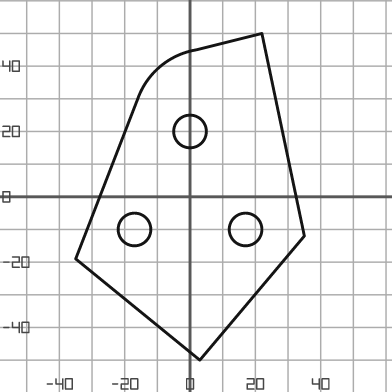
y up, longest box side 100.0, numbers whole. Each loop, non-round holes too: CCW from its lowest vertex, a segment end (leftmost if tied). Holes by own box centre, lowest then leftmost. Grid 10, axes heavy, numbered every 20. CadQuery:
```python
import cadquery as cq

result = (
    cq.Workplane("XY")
    .moveTo(3.0, -50.0)
    .lineTo(35.0, -12.0)
    .lineTo(22.0, 50.0)
    .lineTo(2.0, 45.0)
    .threePointArc((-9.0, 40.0), (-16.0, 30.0))
    .lineTo(-35.0, -19.0)
    .close()
    .moveTo(-17.0, -10.0)
    .circle(5.0)
    .moveTo(17.0, -10.0)
    .circle(5.0)
    .moveTo(0.0, 20.0)
    .circle(5.0)
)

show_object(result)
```